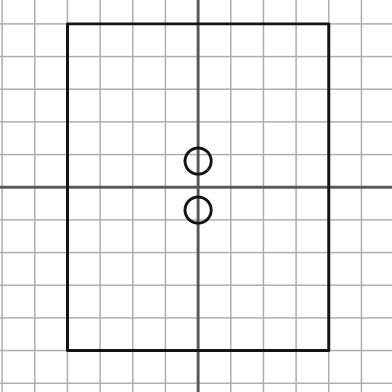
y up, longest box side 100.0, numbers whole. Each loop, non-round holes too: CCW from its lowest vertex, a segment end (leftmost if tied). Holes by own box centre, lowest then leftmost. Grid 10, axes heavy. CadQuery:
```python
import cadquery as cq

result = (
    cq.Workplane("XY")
    .moveTo(-40.0, -50.0)
    .lineTo(40.0, -50.0)
    .lineTo(40.0, 50.0)
    .lineTo(-40.0, 50.0)
    .close()
    .moveTo(0.0, -7.0)
    .circle(4.0)
    .moveTo(0.0, 8.0)
    .circle(4.0)
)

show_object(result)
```